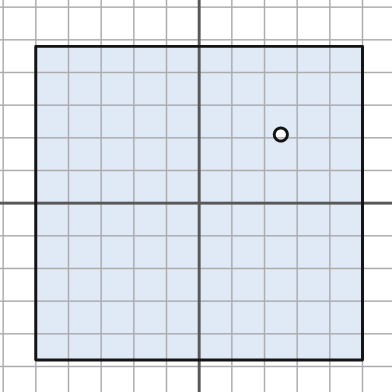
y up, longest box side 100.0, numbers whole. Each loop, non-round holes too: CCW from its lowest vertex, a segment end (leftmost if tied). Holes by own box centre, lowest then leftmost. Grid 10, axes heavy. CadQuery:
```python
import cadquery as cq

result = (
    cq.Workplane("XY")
    .moveTo(-50.0, -48.0)
    .lineTo(50.0, -48.0)
    .lineTo(50.0, 48.0)
    .lineTo(-50.0, 48.0)
    .close()
    .moveTo(25.0, 21.0)
    .circle(2.0)
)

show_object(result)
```